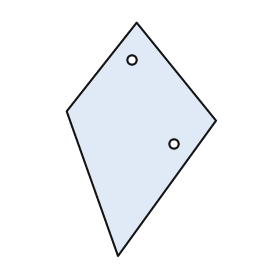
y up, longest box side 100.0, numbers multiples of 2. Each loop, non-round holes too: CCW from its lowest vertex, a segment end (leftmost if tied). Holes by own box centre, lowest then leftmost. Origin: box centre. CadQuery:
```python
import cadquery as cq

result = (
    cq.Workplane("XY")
    .moveTo(-10.0, -50.0)
    .lineTo(32.0, 8.0)
    .lineTo(-2.0, 50.0)
    .lineTo(-32.0, 12.0)
    .close()
    .moveTo(14.0, -2.0)
    .circle(2.0)
    .moveTo(-4.0, 34.0)
    .circle(2.0)
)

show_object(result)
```